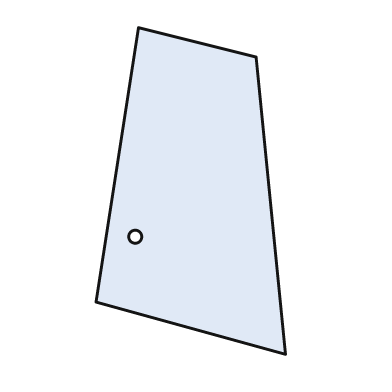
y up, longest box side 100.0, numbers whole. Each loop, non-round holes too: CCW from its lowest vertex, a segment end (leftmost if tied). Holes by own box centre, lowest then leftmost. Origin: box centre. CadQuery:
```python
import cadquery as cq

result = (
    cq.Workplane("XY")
    .moveTo(29.0, -50.0)
    .lineTo(20.0, 41.0)
    .lineTo(-16.0, 50.0)
    .lineTo(-29.0, -34.0)
    .close()
    .moveTo(-17.0, -14.0)
    .circle(2.0)
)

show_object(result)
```